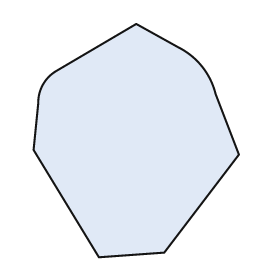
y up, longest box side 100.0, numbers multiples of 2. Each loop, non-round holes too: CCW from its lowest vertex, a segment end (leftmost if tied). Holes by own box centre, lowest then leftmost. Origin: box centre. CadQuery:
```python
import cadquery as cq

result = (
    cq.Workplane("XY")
    .moveTo(-16.0, -50.0)
    .lineTo(12.0, -48.0)
    .lineTo(44.0, -6.0)
    .lineTo(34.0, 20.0)
    .threePointArc((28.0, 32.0), (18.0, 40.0))
    .lineTo(0.0, 50.0)
    .lineTo(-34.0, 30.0)
    .threePointArc((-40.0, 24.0), (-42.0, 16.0))
    .lineTo(-44.0, -4.0)
    .close()
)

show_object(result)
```